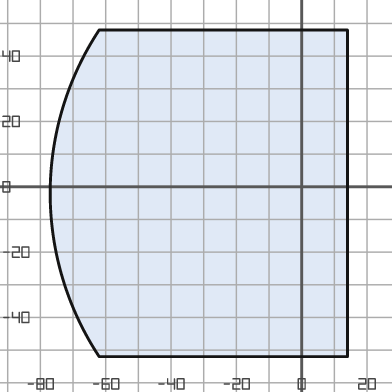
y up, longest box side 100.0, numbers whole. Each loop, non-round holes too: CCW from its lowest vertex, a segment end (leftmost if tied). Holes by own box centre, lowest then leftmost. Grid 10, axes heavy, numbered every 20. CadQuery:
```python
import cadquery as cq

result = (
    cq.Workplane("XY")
    .moveTo(-62.0, -52.0)
    .lineTo(14.0, -52.0)
    .lineTo(14.0, 48.0)
    .lineTo(-62.0, 48.0)
    .threePointArc((-77.0, -2.0), (-62.0, -52.0))
    .close()
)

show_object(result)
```